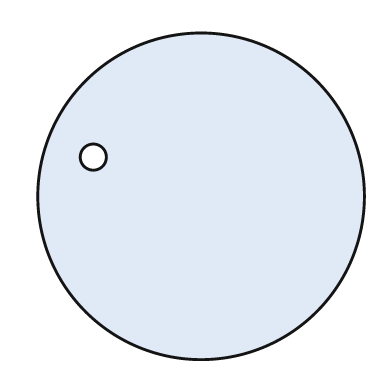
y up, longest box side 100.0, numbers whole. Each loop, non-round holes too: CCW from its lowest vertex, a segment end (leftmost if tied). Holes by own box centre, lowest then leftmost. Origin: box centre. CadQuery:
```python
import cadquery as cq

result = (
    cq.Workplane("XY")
    .moveTo(0.0, 0.0)
    .circle(50.0)
    .moveTo(-33.0, 12.0)
    .circle(4.0)
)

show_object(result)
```